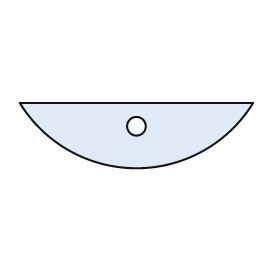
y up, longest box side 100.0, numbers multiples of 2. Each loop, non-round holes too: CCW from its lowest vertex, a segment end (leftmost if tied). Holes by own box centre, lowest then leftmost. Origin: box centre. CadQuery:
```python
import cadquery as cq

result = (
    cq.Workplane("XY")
    .moveTo(-50.0, 14.0)
    .threePointArc((0.0, -14.0), (50.0, 14.0))
    .close()
    .moveTo(0.0, 4.0)
    .circle(4.0)
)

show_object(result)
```